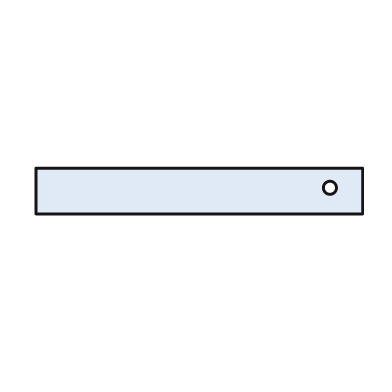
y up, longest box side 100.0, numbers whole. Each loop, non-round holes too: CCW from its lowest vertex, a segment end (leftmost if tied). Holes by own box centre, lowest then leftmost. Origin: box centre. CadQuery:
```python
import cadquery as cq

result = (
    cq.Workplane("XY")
    .moveTo(-50.0, -7.0)
    .lineTo(50.0, -7.0)
    .lineTo(50.0, 7.0)
    .lineTo(-50.0, 7.0)
    .close()
    .moveTo(40.0, 1.0)
    .circle(2.0)
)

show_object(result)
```